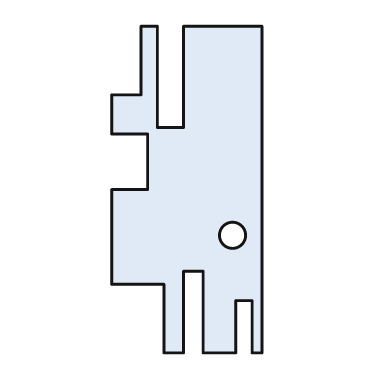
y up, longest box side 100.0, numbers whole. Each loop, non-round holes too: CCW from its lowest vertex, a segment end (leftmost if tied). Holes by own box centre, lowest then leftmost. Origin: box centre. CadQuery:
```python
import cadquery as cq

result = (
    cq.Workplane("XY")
    .moveTo(-7.0, -50.0)
    .lineTo(-1.0, -50.0)
    .lineTo(-1.0, -25.0)
    .lineTo(5.0, -25.0)
    .lineTo(5.0, -50.0)
    .lineTo(15.0, -50.0)
    .lineTo(15.0, -34.0)
    .lineTo(20.0, -34.0)
    .lineTo(20.0, -50.0)
    .lineTo(23.0, -50.0)
    .lineTo(23.0, 50.0)
    .lineTo(-1.0, 50.0)
    .lineTo(-1.0, 19.0)
    .lineTo(-9.0, 19.0)
    .lineTo(-9.0, 50.0)
    .lineTo(-14.0, 50.0)
    .lineTo(-14.0, 29.0)
    .lineTo(-23.0, 29.0)
    .lineTo(-23.0, 17.0)
    .lineTo(-12.0, 17.0)
    .lineTo(-12.0, 0.0)
    .lineTo(-23.0, 0.0)
    .lineTo(-23.0, -29.0)
    .lineTo(-7.0, -29.0)
    .close()
    .moveTo(14.0, -14.0)
    .circle(4.0)
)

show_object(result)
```